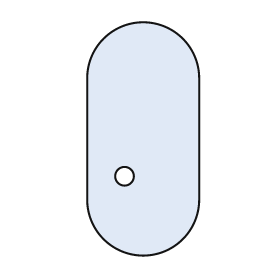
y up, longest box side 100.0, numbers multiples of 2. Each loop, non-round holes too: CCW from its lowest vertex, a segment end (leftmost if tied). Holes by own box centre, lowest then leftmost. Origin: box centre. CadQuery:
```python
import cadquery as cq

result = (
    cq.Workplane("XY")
    .moveTo(-24.0, -26.0)
    .threePointArc((0.0, -50.0), (24.0, -26.0))
    .lineTo(24.0, 26.0)
    .threePointArc((0.0, 50.0), (-24.0, 26.0))
    .close()
    .moveTo(-8.0, -16.0)
    .circle(4.0)
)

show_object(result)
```